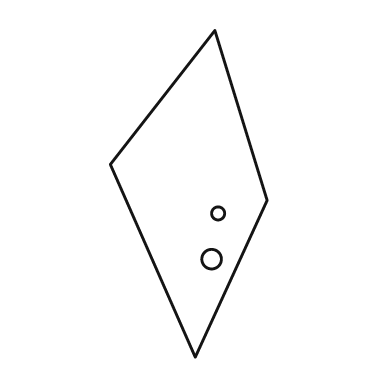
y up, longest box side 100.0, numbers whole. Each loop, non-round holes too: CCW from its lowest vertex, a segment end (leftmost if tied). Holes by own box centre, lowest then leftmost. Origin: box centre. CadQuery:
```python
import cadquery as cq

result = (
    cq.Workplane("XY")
    .moveTo(2.0, -50.0)
    .lineTo(24.0, -2.0)
    .lineTo(8.0, 50.0)
    .lineTo(-24.0, 9.0)
    .close()
    .moveTo(7.0, -20.0)
    .circle(3.0)
    .moveTo(9.0, -6.0)
    .circle(2.0)
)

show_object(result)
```